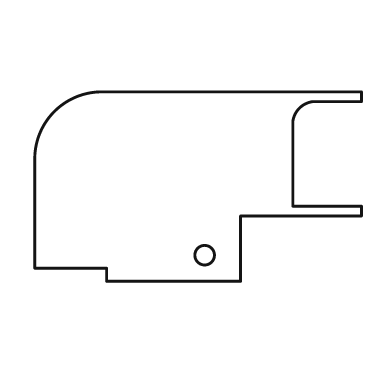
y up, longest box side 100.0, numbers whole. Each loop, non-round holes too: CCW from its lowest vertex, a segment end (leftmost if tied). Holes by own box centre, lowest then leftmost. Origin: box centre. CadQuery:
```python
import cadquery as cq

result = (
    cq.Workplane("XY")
    .moveTo(-28.0, -29.0)
    .lineTo(13.0, -29.0)
    .lineTo(13.0, -9.0)
    .lineTo(50.0, -9.0)
    .lineTo(50.0, -6.0)
    .lineTo(29.0, -6.0)
    .lineTo(29.0, 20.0)
    .threePointArc((31.0, 24.0), (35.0, 26.0))
    .lineTo(50.0, 26.0)
    .lineTo(50.0, 29.0)
    .lineTo(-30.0, 29.0)
    .threePointArc((-44.0, 23.0), (-50.0, 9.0))
    .lineTo(-50.0, -25.0)
    .lineTo(-28.0, -25.0)
    .close()
    .moveTo(2.0, -21.0)
    .circle(3.0)
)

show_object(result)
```